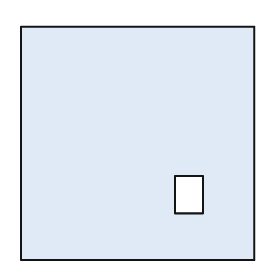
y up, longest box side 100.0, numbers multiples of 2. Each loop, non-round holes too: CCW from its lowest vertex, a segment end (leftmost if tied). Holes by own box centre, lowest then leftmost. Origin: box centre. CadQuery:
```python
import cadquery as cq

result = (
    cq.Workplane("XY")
    .moveTo(-50.0, -50.0)
    .lineTo(50.0, -50.0)
    .lineTo(50.0, 50.0)
    .lineTo(-50.0, 50.0)
    .close()
    .moveTo(16.0, -30.0)
    .lineTo(28.0, -30.0)
    .lineTo(28.0, -14.0)
    .lineTo(16.0, -14.0)
    .close()
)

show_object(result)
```